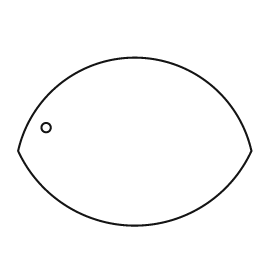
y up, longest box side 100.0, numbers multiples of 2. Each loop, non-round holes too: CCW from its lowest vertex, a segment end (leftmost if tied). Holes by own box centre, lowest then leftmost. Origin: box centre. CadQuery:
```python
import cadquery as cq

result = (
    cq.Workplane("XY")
    .moveTo(-50.0, -4.0)
    .threePointArc((0.0, -36.0), (50.0, -4.0))
    .threePointArc((0.0, 36.0), (-50.0, -4.0))
    .close()
    .moveTo(-38.0, 6.0)
    .circle(2.0)
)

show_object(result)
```